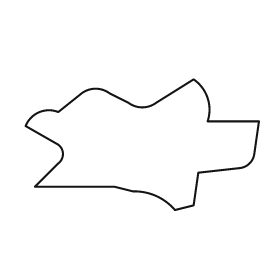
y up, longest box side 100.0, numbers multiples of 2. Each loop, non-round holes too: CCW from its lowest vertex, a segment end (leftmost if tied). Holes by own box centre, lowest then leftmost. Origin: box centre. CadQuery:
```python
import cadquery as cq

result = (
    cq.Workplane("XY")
    .moveTo(14.0, -28.0)
    .lineTo(22.0, -26.0)
    .lineTo(24.0, -12.0)
    .lineTo(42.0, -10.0)
    .threePointArc((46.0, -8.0), (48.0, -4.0))
    .lineTo(50.0, 10.0)
    .lineTo(28.0, 10.0)
    .threePointArc((28.0, 20.0), (22.0, 28.0))
    .lineTo(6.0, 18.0)
    .threePointArc((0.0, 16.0), (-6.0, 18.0))
    .lineTo(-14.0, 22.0)
    .threePointArc((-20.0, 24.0), (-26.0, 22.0))
    .lineTo(-36.0, 14.0)
    .threePointArc((-44.0, 14.0), (-50.0, 8.0))
    .lineTo(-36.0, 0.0)
    .threePointArc((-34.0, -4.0), (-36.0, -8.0))
    .lineTo(-46.0, -18.0)
    .lineTo(-12.0, -18.0)
    .lineTo(-4.0, -20.0)
    .threePointArc((6.0, -22.0), (14.0, -28.0))
    .close()
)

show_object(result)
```